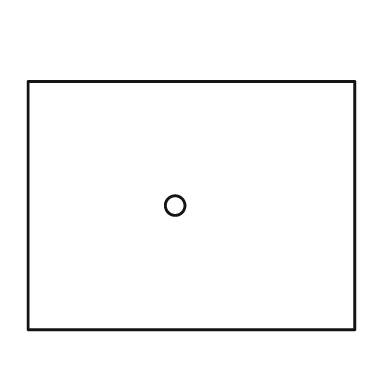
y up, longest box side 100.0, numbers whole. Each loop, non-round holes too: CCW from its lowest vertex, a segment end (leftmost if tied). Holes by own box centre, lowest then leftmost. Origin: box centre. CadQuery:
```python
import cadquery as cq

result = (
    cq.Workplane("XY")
    .moveTo(-50.0, -38.0)
    .lineTo(50.0, -38.0)
    .lineTo(50.0, 38.0)
    .lineTo(-50.0, 38.0)
    .close()
    .moveTo(-5.0, 0.0)
    .circle(3.0)
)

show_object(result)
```